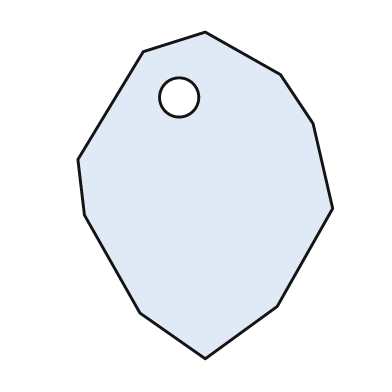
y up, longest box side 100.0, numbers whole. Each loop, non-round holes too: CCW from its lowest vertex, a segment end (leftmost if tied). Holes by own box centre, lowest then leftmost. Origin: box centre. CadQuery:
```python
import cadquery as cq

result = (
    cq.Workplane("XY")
    .moveTo(0.0, -50.0)
    .lineTo(22.0, -34.0)
    .lineTo(39.0, -4.0)
    .lineTo(33.0, 22.0)
    .lineTo(23.0, 37.0)
    .lineTo(0.0, 50.0)
    .lineTo(-19.0, 44.0)
    .lineTo(-39.0, 11.0)
    .lineTo(-37.0, -6.0)
    .lineTo(-20.0, -36.0)
    .close()
    .moveTo(-8.0, 30.0)
    .circle(6.0)
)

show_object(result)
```